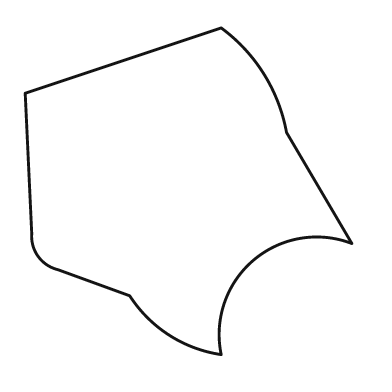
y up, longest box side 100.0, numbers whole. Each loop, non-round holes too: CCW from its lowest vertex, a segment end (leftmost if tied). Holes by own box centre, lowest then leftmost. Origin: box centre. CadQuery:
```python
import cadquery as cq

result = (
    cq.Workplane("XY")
    .moveTo(10.0, -50.0)
    .threePointArc((20.0, -21.0), (50.0, -16.0))
    .lineTo(30.0, 18.0)
    .threePointArc((23.0, 36.0), (10.0, 50.0))
    .lineTo(-50.0, 30.0)
    .lineTo(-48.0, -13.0)
    .threePointArc((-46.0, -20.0), (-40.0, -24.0))
    .lineTo(-18.0, -32.0)
    .threePointArc((-6.0, -44.0), (10.0, -50.0))
    .close()
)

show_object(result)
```